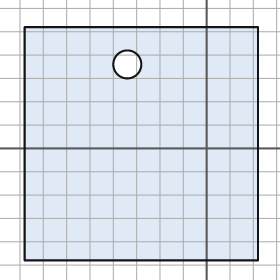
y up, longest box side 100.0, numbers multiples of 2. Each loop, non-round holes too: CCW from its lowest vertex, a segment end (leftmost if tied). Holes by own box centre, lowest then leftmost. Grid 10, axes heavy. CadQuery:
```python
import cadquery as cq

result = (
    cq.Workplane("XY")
    .moveTo(-78.0, -48.0)
    .lineTo(22.0, -48.0)
    .lineTo(22.0, 52.0)
    .lineTo(-78.0, 52.0)
    .close()
    .moveTo(-34.0, 36.0)
    .circle(6.0)
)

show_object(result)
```